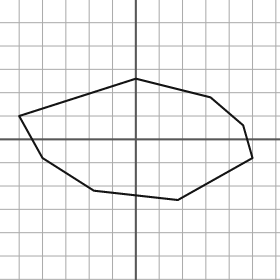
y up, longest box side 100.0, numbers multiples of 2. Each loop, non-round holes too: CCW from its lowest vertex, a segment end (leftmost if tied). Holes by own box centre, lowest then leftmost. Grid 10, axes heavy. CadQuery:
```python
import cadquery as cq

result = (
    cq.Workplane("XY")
    .moveTo(18.0, -26.0)
    .lineTo(50.0, -8.0)
    .lineTo(46.0, 6.0)
    .lineTo(32.0, 18.0)
    .lineTo(0.0, 26.0)
    .lineTo(-50.0, 10.0)
    .lineTo(-40.0, -8.0)
    .lineTo(-18.0, -22.0)
    .close()
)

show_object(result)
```